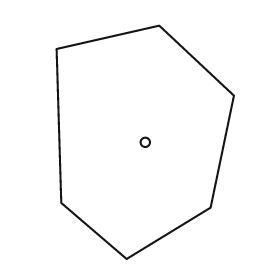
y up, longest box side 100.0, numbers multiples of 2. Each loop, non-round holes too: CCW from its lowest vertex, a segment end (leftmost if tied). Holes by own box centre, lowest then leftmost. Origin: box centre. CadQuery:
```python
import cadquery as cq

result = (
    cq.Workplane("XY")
    .moveTo(-8.0, -50.0)
    .lineTo(28.0, -28.0)
    .lineTo(38.0, 20.0)
    .lineTo(6.0, 50.0)
    .lineTo(-38.0, 40.0)
    .lineTo(-36.0, -26.0)
    .close()
    .moveTo(0.0, 0.0)
    .circle(2.0)
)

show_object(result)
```